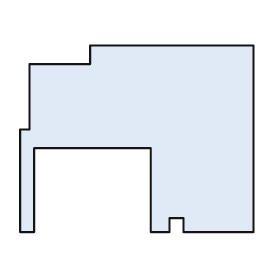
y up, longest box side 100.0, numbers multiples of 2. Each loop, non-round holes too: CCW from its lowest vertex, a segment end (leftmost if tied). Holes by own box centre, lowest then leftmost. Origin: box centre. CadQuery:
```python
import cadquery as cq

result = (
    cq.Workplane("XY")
    .moveTo(-50.0, -40.0)
    .lineTo(-44.0, -40.0)
    .lineTo(-44.0, -4.0)
    .lineTo(6.0, -4.0)
    .lineTo(6.0, -40.0)
    .lineTo(14.0, -40.0)
    .lineTo(14.0, -34.0)
    .lineTo(20.0, -34.0)
    .lineTo(20.0, -40.0)
    .lineTo(50.0, -40.0)
    .lineTo(50.0, 40.0)
    .lineTo(-20.0, 40.0)
    .lineTo(-20.0, 32.0)
    .lineTo(-46.0, 32.0)
    .lineTo(-46.0, 4.0)
    .lineTo(-50.0, 4.0)
    .close()
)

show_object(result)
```